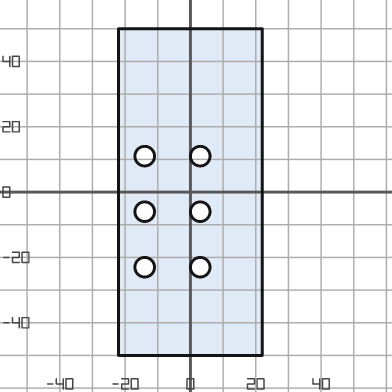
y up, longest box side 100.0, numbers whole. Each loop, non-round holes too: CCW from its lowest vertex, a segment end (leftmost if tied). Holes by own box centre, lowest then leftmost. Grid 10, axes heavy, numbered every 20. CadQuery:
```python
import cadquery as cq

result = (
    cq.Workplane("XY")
    .moveTo(-22.0, -50.0)
    .lineTo(22.0, -50.0)
    .lineTo(22.0, 50.0)
    .lineTo(-22.0, 50.0)
    .close()
    .moveTo(-14.0, -23.0)
    .circle(3.0)
    .moveTo(3.0, -23.0)
    .circle(3.0)
    .moveTo(-14.0, -6.0)
    .circle(3.0)
    .moveTo(3.0, -6.0)
    .circle(3.0)
    .moveTo(-14.0, 11.0)
    .circle(3.0)
    .moveTo(3.0, 11.0)
    .circle(3.0)
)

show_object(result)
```